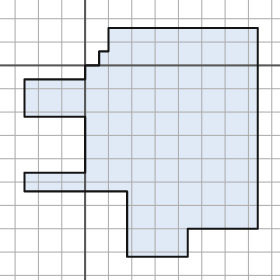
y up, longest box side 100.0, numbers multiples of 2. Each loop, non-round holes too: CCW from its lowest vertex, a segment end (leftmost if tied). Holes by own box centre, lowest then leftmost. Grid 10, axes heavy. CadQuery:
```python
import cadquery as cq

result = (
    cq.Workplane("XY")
    .moveTo(18.0, -82.0)
    .lineTo(44.0, -82.0)
    .lineTo(44.0, -70.0)
    .lineTo(74.0, -70.0)
    .lineTo(74.0, 16.0)
    .lineTo(10.0, 16.0)
    .lineTo(10.0, 6.0)
    .lineTo(6.0, 6.0)
    .lineTo(6.0, 0.0)
    .lineTo(0.0, 0.0)
    .lineTo(0.0, -6.0)
    .lineTo(-26.0, -6.0)
    .lineTo(-26.0, -22.0)
    .lineTo(0.0, -22.0)
    .lineTo(0.0, -46.0)
    .lineTo(-26.0, -46.0)
    .lineTo(-26.0, -54.0)
    .lineTo(18.0, -54.0)
    .close()
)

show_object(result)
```